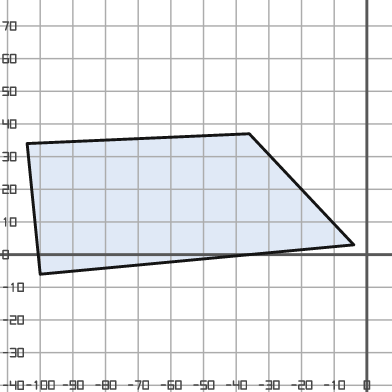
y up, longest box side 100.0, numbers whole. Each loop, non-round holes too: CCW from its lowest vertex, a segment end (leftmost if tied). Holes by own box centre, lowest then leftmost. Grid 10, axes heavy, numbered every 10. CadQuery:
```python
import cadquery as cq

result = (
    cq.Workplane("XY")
    .moveTo(-100.0, -6.0)
    .lineTo(-4.0, 3.0)
    .lineTo(-36.0, 37.0)
    .lineTo(-104.0, 34.0)
    .close()
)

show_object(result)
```